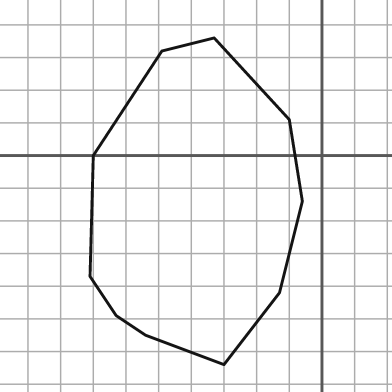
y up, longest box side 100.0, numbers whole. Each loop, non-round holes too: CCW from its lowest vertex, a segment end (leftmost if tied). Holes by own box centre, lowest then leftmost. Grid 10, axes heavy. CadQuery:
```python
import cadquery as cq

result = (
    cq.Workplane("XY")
    .moveTo(-30.0, -64.0)
    .lineTo(-13.0, -42.0)
    .lineTo(-6.0, -14.0)
    .lineTo(-10.0, 11.0)
    .lineTo(-33.0, 36.0)
    .lineTo(-49.0, 32.0)
    .lineTo(-70.0, 0.0)
    .lineTo(-71.0, -37.0)
    .lineTo(-63.0, -49.0)
    .lineTo(-54.0, -55.0)
    .close()
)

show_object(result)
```